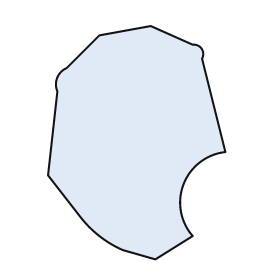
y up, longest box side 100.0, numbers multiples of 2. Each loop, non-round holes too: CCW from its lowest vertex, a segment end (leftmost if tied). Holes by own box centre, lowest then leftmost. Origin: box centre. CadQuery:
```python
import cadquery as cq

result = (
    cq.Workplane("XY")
    .moveTo(8.0, -50.0)
    .lineTo(24.0, -40.0)
    .threePointArc((20.0, -18.0), (38.0, -4.0))
    .lineTo(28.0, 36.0)
    .threePointArc((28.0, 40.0), (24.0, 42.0))
    .lineTo(6.0, 50.0)
    .lineTo(-16.0, 46.0)
    .lineTo(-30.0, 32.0)
    .threePointArc((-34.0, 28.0), (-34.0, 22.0))
    .lineTo(-38.0, -14.0)
    .lineTo(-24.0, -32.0)
    .threePointArc((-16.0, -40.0), (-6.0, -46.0))
    .close()
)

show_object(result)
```